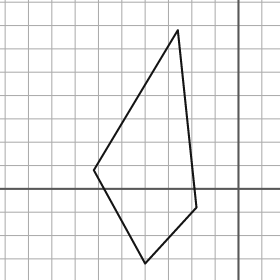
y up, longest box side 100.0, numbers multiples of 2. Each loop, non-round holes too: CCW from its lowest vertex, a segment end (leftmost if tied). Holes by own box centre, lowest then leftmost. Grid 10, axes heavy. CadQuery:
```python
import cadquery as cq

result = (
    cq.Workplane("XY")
    .moveTo(-40.0, -32.0)
    .lineTo(-18.0, -8.0)
    .lineTo(-26.0, 68.0)
    .lineTo(-62.0, 8.0)
    .close()
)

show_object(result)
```